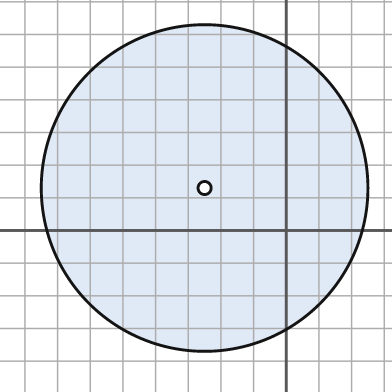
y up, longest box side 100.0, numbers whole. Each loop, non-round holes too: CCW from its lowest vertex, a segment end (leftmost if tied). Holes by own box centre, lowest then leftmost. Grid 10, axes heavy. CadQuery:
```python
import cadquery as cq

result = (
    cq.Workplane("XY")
    .moveTo(-25.0, 13.0)
    .circle(50.0)
    .moveTo(-25.0, 13.0)
    .circle(2.0)
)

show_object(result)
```